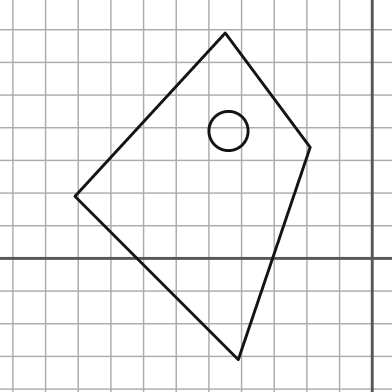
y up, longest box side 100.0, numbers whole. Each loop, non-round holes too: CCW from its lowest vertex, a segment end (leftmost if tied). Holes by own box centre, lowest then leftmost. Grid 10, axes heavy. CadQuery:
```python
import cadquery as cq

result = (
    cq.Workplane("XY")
    .moveTo(-41.0, -31.0)
    .lineTo(-19.0, 34.0)
    .lineTo(-45.0, 69.0)
    .lineTo(-91.0, 19.0)
    .close()
    .moveTo(-44.0, 39.0)
    .circle(6.0)
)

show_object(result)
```